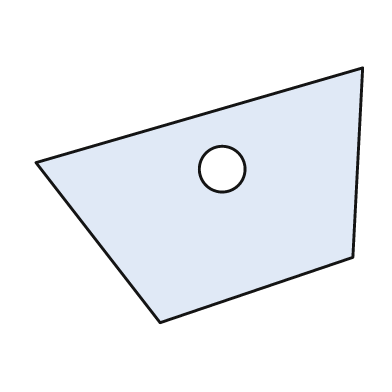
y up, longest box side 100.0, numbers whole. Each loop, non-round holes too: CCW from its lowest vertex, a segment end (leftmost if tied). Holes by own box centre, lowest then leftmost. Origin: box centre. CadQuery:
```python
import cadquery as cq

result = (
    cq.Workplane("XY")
    .moveTo(-12.0, -39.0)
    .lineTo(47.0, -19.0)
    .lineTo(50.0, 39.0)
    .lineTo(-50.0, 10.0)
    .close()
    .moveTo(7.0, 8.0)
    .circle(7.0)
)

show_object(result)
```